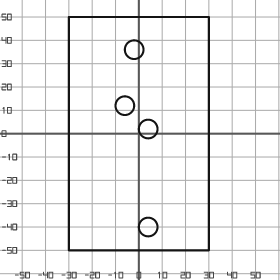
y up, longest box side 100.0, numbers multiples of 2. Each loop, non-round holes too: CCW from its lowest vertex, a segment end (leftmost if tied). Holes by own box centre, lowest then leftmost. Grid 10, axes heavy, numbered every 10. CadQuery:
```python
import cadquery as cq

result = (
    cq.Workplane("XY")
    .moveTo(-30.0, -50.0)
    .lineTo(30.0, -50.0)
    .lineTo(30.0, 50.0)
    .lineTo(-30.0, 50.0)
    .close()
    .moveTo(4.0, -40.0)
    .circle(4.0)
    .moveTo(4.0, 2.0)
    .circle(4.0)
    .moveTo(-6.0, 12.0)
    .circle(4.0)
    .moveTo(-2.0, 36.0)
    .circle(4.0)
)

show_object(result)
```